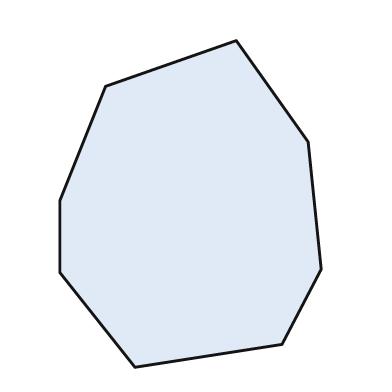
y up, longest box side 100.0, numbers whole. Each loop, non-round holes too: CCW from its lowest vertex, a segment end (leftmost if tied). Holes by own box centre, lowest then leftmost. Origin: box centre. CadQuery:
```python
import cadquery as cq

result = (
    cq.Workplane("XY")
    .moveTo(-17.0, -50.0)
    .lineTo(28.0, -43.0)
    .lineTo(40.0, -20.0)
    .lineTo(36.0, 19.0)
    .lineTo(14.0, 50.0)
    .lineTo(-26.0, 36.0)
    .lineTo(-40.0, 1.0)
    .lineTo(-40.0, -21.0)
    .close()
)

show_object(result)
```